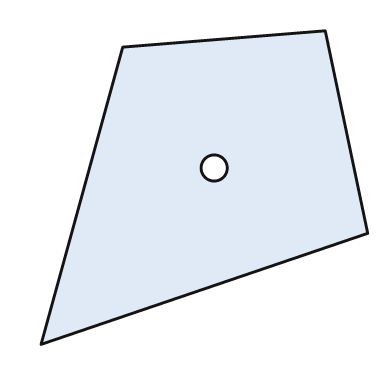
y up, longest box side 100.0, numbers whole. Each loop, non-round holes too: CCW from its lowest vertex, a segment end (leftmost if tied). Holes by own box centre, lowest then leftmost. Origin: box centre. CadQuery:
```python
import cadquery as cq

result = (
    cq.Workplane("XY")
    .moveTo(-50.0, -48.0)
    .lineTo(50.0, -14.0)
    .lineTo(37.0, 48.0)
    .lineTo(-25.0, 43.0)
    .close()
    .moveTo(3.0, 6.0)
    .circle(4.0)
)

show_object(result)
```